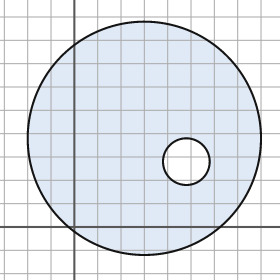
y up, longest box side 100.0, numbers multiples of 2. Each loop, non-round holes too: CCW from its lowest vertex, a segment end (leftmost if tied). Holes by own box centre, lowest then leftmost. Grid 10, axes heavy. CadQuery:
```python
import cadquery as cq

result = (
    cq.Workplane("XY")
    .moveTo(30.0, 38.0)
    .circle(50.0)
    .moveTo(48.0, 28.0)
    .circle(10.0)
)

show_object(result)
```